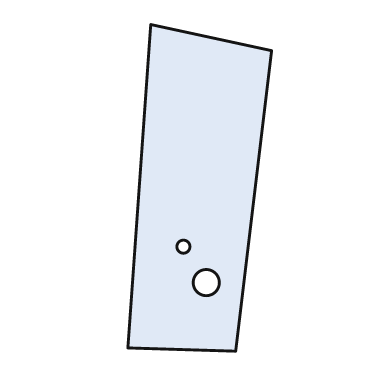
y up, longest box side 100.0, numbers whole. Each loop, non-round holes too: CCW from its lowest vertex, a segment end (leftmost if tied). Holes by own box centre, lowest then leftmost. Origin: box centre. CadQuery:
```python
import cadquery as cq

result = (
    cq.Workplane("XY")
    .moveTo(11.0, -50.0)
    .lineTo(22.0, 42.0)
    .lineTo(-15.0, 50.0)
    .lineTo(-22.0, -49.0)
    .close()
    .moveTo(2.0, -29.0)
    .circle(4.0)
    .moveTo(-5.0, -18.0)
    .circle(2.0)
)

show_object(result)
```